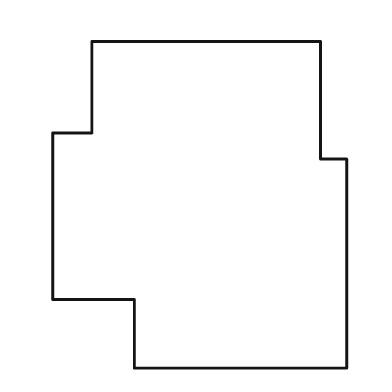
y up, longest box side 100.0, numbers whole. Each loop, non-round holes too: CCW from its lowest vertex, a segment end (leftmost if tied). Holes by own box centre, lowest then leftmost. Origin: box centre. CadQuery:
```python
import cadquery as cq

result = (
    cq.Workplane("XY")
    .moveTo(-20.0, -50.0)
    .lineTo(45.0, -50.0)
    .lineTo(45.0, 14.0)
    .lineTo(37.0, 14.0)
    .lineTo(37.0, 50.0)
    .lineTo(-33.0, 50.0)
    .lineTo(-33.0, 22.0)
    .lineTo(-45.0, 22.0)
    .lineTo(-45.0, -29.0)
    .lineTo(-20.0, -29.0)
    .close()
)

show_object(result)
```